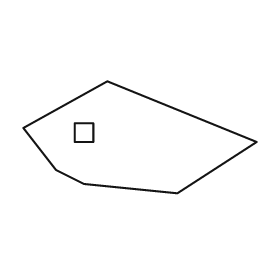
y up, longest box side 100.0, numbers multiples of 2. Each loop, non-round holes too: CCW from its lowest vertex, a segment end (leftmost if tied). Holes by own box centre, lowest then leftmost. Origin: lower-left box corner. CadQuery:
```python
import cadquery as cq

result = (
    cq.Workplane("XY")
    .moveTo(66.0, 0.0)
    .lineTo(100.0, 22.0)
    .lineTo(36.0, 48.0)
    .lineTo(0.0, 28.0)
    .lineTo(14.0, 10.0)
    .lineTo(26.0, 4.0)
    .close()
    .moveTo(22.0, 22.0)
    .lineTo(30.0, 22.0)
    .lineTo(30.0, 30.0)
    .lineTo(22.0, 30.0)
    .close()
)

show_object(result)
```